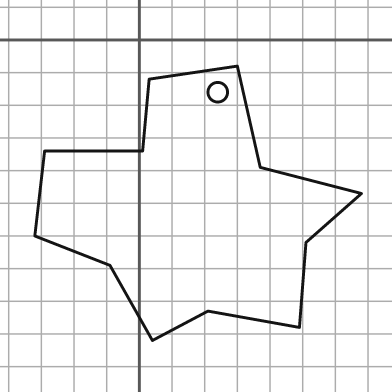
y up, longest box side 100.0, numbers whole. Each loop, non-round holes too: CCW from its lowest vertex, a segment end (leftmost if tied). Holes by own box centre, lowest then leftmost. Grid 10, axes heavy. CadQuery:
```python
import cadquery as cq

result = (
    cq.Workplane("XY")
    .moveTo(4.0, -92.0)
    .lineTo(21.0, -83.0)
    .lineTo(49.0, -88.0)
    .lineTo(51.0, -62.0)
    .lineTo(68.0, -47.0)
    .lineTo(37.0, -39.0)
    .lineTo(30.0, -8.0)
    .lineTo(3.0, -12.0)
    .lineTo(1.0, -34.0)
    .lineTo(-29.0, -34.0)
    .lineTo(-32.0, -60.0)
    .lineTo(-9.0, -69.0)
    .close()
    .moveTo(24.0, -16.0)
    .circle(3.0)
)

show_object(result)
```